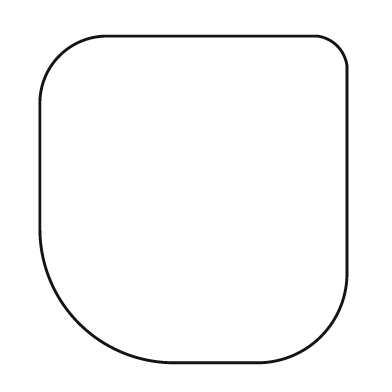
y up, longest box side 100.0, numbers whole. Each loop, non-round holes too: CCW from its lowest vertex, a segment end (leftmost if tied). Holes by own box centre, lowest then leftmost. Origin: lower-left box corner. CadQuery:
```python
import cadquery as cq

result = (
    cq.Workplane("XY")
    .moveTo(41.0, 0.0)
    .lineTo(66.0, 0.0)
    .threePointArc((86.0, 8.0), (94.0, 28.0))
    .lineTo(94.0, 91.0)
    .threePointArc((91.0, 97.0), (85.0, 100.0))
    .lineTo(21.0, 100.0)
    .threePointArc((6.0, 94.0), (0.0, 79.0))
    .lineTo(0.0, 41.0)
    .threePointArc((12.0, 12.0), (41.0, 0.0))
    .close()
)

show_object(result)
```